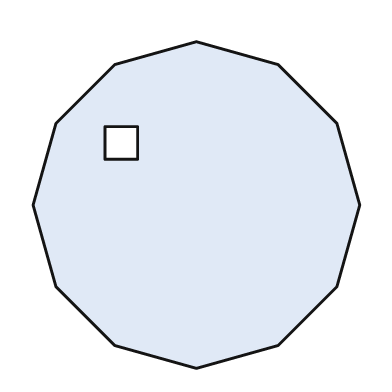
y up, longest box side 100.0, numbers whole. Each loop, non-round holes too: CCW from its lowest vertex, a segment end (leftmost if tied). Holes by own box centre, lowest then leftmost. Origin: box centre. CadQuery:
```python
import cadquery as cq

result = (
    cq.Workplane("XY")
    .moveTo(0.0, -50.0)
    .lineTo(25.0, -43.0)
    .lineTo(43.0, -25.0)
    .lineTo(50.0, 0.0)
    .lineTo(43.0, 25.0)
    .lineTo(25.0, 43.0)
    .lineTo(0.0, 50.0)
    .lineTo(-25.0, 43.0)
    .lineTo(-43.0, 25.0)
    .lineTo(-50.0, 0.0)
    .lineTo(-43.0, -25.0)
    .lineTo(-25.0, -43.0)
    .close()
    .moveTo(-28.0, 14.0)
    .lineTo(-18.0, 14.0)
    .lineTo(-18.0, 24.0)
    .lineTo(-28.0, 24.0)
    .close()
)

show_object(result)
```